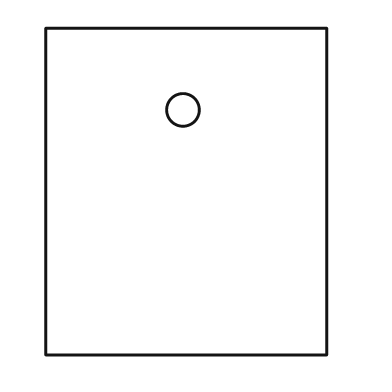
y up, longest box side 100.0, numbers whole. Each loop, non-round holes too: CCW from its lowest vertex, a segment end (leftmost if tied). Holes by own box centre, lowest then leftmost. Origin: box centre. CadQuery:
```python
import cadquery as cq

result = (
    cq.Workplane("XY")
    .moveTo(-43.0, -50.0)
    .lineTo(43.0, -50.0)
    .lineTo(43.0, 50.0)
    .lineTo(-43.0, 50.0)
    .close()
    .moveTo(-1.0, 25.0)
    .circle(5.0)
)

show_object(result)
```